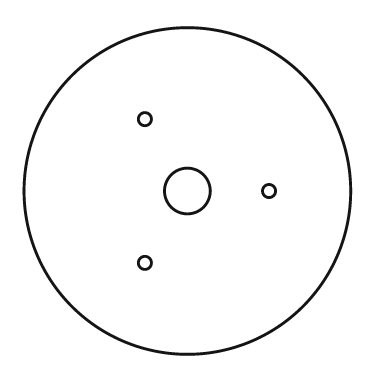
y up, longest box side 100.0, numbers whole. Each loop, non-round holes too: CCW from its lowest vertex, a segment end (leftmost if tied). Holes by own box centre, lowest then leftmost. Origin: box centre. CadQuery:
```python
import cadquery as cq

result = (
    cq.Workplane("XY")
    .moveTo(0.0, 0.0)
    .circle(50.0)
    .moveTo(-13.0, -22.0)
    .circle(2.0)
    .moveTo(0.0, 0.0)
    .circle(7.0)
    .moveTo(25.0, 0.0)
    .circle(2.0)
    .moveTo(-13.0, 22.0)
    .circle(2.0)
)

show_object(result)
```